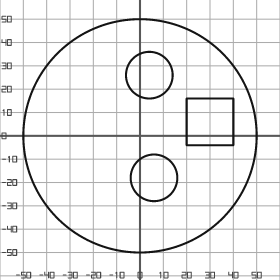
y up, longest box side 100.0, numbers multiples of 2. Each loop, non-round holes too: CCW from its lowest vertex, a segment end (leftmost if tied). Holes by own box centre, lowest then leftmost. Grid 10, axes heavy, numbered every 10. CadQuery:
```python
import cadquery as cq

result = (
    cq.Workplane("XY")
    .moveTo(0.0, 0.0)
    .circle(50.0)
    .moveTo(6.0, -18.0)
    .circle(10.0)
    .moveTo(20.0, -4.0)
    .lineTo(40.0, -4.0)
    .lineTo(40.0, 16.0)
    .lineTo(20.0, 16.0)
    .close()
    .moveTo(4.0, 26.0)
    .circle(10.0)
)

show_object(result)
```